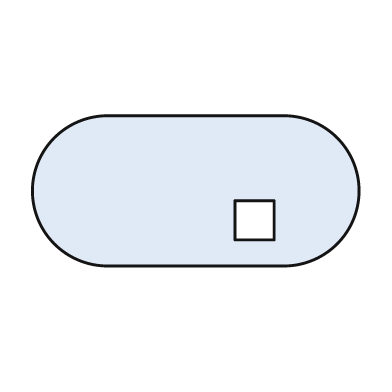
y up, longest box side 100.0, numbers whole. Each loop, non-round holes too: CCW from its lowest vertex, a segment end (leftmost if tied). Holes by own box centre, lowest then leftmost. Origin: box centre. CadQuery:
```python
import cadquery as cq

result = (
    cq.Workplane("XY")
    .moveTo(-27.0, -23.0)
    .lineTo(27.0, -23.0)
    .threePointArc((50.0, 0.0), (27.0, 23.0))
    .lineTo(-27.0, 23.0)
    .threePointArc((-50.0, 0.0), (-27.0, -23.0))
    .close()
    .moveTo(12.0, -15.0)
    .lineTo(24.0, -15.0)
    .lineTo(24.0, -3.0)
    .lineTo(12.0, -3.0)
    .close()
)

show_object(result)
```